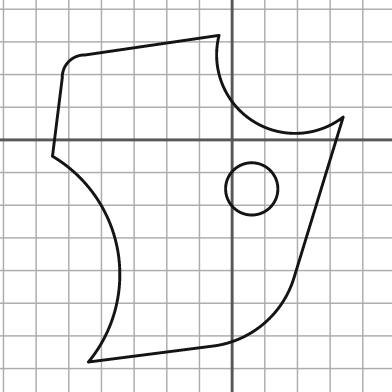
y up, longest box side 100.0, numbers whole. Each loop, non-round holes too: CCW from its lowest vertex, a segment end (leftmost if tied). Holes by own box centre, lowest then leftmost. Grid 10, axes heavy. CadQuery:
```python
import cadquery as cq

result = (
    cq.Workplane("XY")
    .moveTo(-44.0, -68.0)
    .lineTo(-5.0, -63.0)
    .threePointArc((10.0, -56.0), (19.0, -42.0))
    .lineTo(34.0, 7.0)
    .threePointArc((6.0, 6.0), (-4.0, 32.0))
    .lineTo(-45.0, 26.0)
    .threePointArc((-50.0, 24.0), (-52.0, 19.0))
    .lineTo(-55.0, -5.0)
    .threePointArc((-35.0, -34.0), (-44.0, -68.0))
    .close()
    .moveTo(6.0, -15.0)
    .circle(8.0)
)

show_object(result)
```